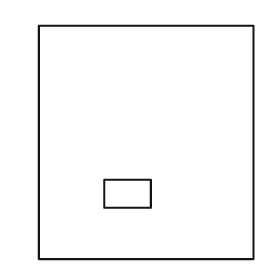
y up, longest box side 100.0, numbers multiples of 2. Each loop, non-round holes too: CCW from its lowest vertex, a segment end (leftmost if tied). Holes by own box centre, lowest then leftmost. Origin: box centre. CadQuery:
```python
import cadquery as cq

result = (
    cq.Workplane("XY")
    .moveTo(-46.0, -50.0)
    .lineTo(46.0, -50.0)
    .lineTo(46.0, 50.0)
    .lineTo(-46.0, 50.0)
    .close()
    .moveTo(-18.0, -28.0)
    .lineTo(2.0, -28.0)
    .lineTo(2.0, -16.0)
    .lineTo(-18.0, -16.0)
    .close()
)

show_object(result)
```